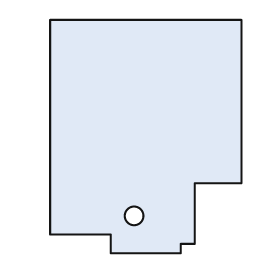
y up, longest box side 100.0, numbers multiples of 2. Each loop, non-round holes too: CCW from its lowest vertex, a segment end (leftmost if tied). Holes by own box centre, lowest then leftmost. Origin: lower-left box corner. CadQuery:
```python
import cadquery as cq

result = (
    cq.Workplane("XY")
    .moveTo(26.0, 0.0)
    .lineTo(56.0, 0.0)
    .lineTo(56.0, 4.0)
    .lineTo(62.0, 4.0)
    .lineTo(62.0, 30.0)
    .lineTo(82.0, 30.0)
    .lineTo(82.0, 100.0)
    .lineTo(0.0, 100.0)
    .lineTo(0.0, 8.0)
    .lineTo(26.0, 8.0)
    .close()
    .moveTo(36.0, 16.0)
    .circle(4.0)
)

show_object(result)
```